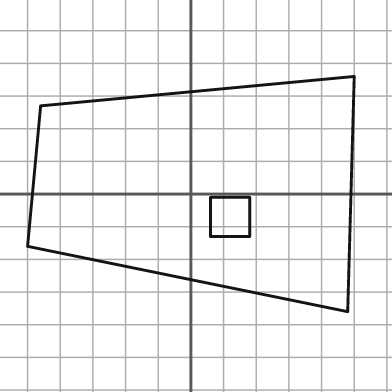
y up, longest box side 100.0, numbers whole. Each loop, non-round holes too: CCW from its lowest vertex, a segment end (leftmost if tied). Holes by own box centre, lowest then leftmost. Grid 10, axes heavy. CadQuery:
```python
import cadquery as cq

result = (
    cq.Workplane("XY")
    .moveTo(48.0, -36.0)
    .lineTo(50.0, 36.0)
    .lineTo(-46.0, 27.0)
    .lineTo(-50.0, -16.0)
    .close()
    .moveTo(6.0, -13.0)
    .lineTo(18.0, -13.0)
    .lineTo(18.0, -1.0)
    .lineTo(6.0, -1.0)
    .close()
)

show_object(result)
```